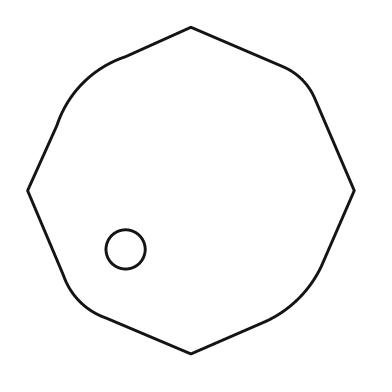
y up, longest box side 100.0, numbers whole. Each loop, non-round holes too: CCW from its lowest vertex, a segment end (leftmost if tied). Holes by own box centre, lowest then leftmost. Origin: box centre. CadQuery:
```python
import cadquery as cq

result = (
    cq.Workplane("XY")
    .moveTo(0.0, -50.0)
    .lineTo(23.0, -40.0)
    .threePointArc((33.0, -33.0), (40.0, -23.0))
    .lineTo(50.0, 0.0)
    .lineTo(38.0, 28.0)
    .threePointArc((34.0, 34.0), (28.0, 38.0))
    .lineTo(0.0, 50.0)
    .lineTo(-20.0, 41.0)
    .threePointArc((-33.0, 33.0), (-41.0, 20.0))
    .lineTo(-50.0, 0.0)
    .lineTo(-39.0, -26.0)
    .threePointArc((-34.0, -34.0), (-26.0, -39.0))
    .close()
    .moveTo(-20.0, -18.0)
    .circle(6.0)
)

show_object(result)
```